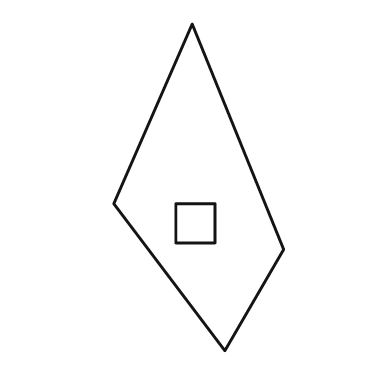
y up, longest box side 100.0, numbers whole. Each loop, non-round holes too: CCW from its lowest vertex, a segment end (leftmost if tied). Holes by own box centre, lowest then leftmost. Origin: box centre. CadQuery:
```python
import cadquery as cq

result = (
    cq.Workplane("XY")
    .moveTo(8.0, -50.0)
    .lineTo(26.0, -19.0)
    .lineTo(-2.0, 50.0)
    .lineTo(-26.0, -5.0)
    .close()
    .moveTo(-7.0, -17.0)
    .lineTo(5.0, -17.0)
    .lineTo(5.0, -5.0)
    .lineTo(-7.0, -5.0)
    .close()
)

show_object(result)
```